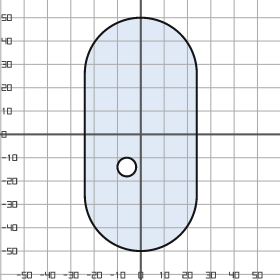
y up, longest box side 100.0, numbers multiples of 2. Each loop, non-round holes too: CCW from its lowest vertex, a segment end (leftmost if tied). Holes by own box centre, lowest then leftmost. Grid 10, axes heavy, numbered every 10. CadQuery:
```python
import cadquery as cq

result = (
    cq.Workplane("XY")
    .moveTo(-24.0, -26.0)
    .threePointArc((0.0, -50.0), (24.0, -26.0))
    .lineTo(24.0, 26.0)
    .threePointArc((0.0, 50.0), (-24.0, 26.0))
    .close()
    .moveTo(-6.0, -14.0)
    .circle(4.0)
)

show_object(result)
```